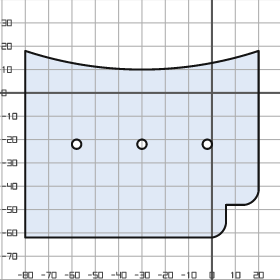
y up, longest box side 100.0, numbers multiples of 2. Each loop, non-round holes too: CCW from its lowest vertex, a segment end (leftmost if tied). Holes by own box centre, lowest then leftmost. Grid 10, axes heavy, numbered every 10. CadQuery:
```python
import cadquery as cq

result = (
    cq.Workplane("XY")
    .moveTo(-80.0, -62.0)
    .lineTo(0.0, -62.0)
    .threePointArc((4.0, -60.0), (6.0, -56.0))
    .lineTo(6.0, -48.0)
    .lineTo(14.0, -48.0)
    .threePointArc((18.0, -46.0), (20.0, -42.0))
    .lineTo(20.0, 18.0)
    .threePointArc((-30.0, 10.0), (-80.0, 18.0))
    .close()
    .moveTo(-58.0, -22.0)
    .circle(2.0)
    .moveTo(-30.0, -22.0)
    .circle(2.0)
    .moveTo(-2.0, -22.0)
    .circle(2.0)
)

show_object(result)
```